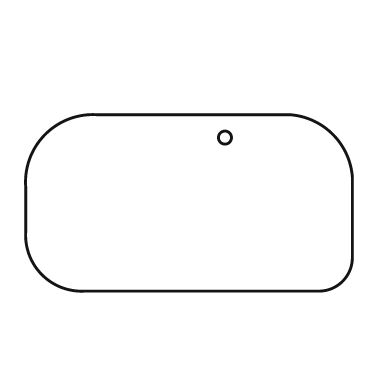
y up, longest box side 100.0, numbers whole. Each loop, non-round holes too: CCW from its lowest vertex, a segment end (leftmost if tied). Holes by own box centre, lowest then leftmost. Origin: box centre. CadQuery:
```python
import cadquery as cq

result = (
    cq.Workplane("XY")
    .moveTo(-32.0, -27.0)
    .lineTo(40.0, -27.0)
    .threePointArc((47.0, -24.0), (50.0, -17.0))
    .lineTo(50.0, 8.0)
    .threePointArc((44.0, 21.0), (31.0, 27.0))
    .lineTo(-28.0, 27.0)
    .threePointArc((-44.0, 21.0), (-50.0, 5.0))
    .lineTo(-50.0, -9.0)
    .threePointArc((-45.0, -22.0), (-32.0, -27.0))
    .close()
    .moveTo(11.0, 20.0)
    .circle(2.0)
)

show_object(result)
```